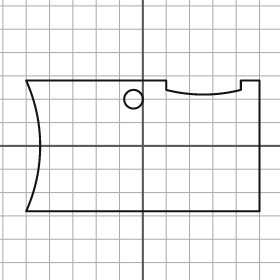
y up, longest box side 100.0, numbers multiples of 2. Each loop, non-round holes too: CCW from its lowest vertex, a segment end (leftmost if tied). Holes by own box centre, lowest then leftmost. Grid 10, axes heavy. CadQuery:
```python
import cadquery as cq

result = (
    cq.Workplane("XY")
    .moveTo(-50.0, -28.0)
    .lineTo(50.0, -28.0)
    .lineTo(50.0, 28.0)
    .lineTo(42.0, 28.0)
    .lineTo(42.0, 24.0)
    .threePointArc((26.0, 22.0), (10.0, 24.0))
    .lineTo(10.0, 28.0)
    .lineTo(-50.0, 28.0)
    .threePointArc((-44.0, 0.0), (-50.0, -28.0))
    .close()
    .moveTo(-4.0, 20.0)
    .circle(4.0)
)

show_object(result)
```